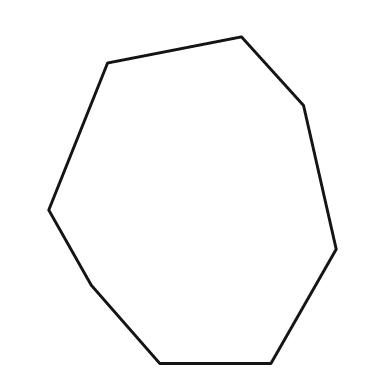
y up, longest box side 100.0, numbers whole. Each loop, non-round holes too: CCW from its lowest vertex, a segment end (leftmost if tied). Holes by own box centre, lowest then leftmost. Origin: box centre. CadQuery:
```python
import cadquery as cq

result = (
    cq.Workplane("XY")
    .moveTo(-10.0, -50.0)
    .lineTo(24.0, -50.0)
    .lineTo(44.0, -15.0)
    .lineTo(34.0, 29.0)
    .lineTo(15.0, 50.0)
    .lineTo(-26.0, 42.0)
    .lineTo(-44.0, -3.0)
    .lineTo(-31.0, -26.0)
    .close()
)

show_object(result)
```